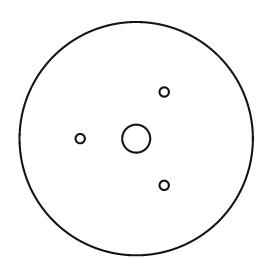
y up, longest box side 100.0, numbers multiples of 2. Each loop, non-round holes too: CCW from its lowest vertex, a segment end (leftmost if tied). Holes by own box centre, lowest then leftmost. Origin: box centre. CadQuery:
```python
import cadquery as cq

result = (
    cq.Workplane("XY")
    .moveTo(0.0, 0.0)
    .circle(50.0)
    .moveTo(12.0, -20.0)
    .circle(2.0)
    .moveTo(-24.0, 0.0)
    .circle(2.0)
    .moveTo(0.0, 0.0)
    .circle(6.0)
    .moveTo(12.0, 20.0)
    .circle(2.0)
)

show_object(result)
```